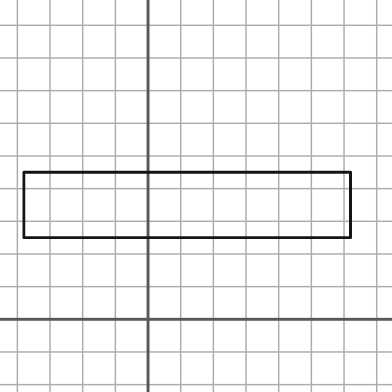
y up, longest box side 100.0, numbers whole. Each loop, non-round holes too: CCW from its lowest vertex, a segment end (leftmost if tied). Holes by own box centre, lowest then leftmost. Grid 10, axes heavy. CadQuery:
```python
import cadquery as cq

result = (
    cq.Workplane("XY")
    .moveTo(-38.0, 25.0)
    .lineTo(62.0, 25.0)
    .lineTo(62.0, 45.0)
    .lineTo(-38.0, 45.0)
    .close()
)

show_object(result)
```